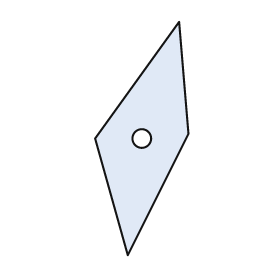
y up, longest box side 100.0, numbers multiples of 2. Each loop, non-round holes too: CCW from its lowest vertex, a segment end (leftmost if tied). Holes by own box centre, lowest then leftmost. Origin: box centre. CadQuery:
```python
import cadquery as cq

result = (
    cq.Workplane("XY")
    .moveTo(-6.0, -50.0)
    .lineTo(20.0, 2.0)
    .lineTo(16.0, 50.0)
    .lineTo(-20.0, 0.0)
    .close()
    .moveTo(0.0, 0.0)
    .circle(4.0)
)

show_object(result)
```